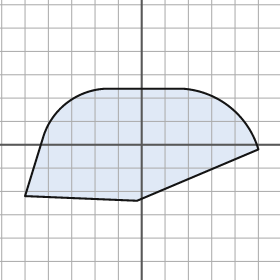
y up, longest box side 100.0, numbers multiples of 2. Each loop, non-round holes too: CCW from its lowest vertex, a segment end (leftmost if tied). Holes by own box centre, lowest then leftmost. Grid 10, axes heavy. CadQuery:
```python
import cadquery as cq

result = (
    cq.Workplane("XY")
    .moveTo(-2.0, -24.0)
    .lineTo(50.0, -2.0)
    .threePointArc((38.0, 16.0), (18.0, 24.0))
    .lineTo(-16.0, 24.0)
    .threePointArc((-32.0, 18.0), (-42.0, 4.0))
    .lineTo(-50.0, -22.0)
    .close()
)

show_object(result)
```